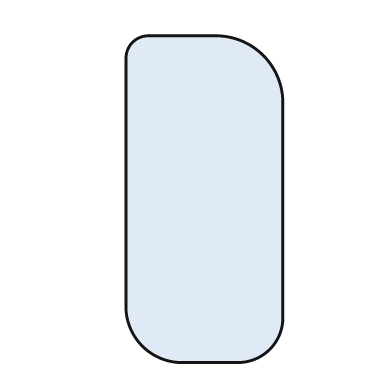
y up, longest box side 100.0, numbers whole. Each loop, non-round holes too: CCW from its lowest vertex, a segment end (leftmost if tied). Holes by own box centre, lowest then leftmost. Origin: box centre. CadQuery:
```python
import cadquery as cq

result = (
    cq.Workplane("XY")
    .moveTo(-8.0, -50.0)
    .lineTo(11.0, -50.0)
    .threePointArc((20.0, -46.0), (24.0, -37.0))
    .lineTo(24.0, 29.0)
    .threePointArc((18.0, 44.0), (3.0, 50.0))
    .lineTo(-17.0, 50.0)
    .threePointArc((-22.0, 48.0), (-24.0, 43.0))
    .lineTo(-24.0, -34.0)
    .threePointArc((-19.0, -45.0), (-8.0, -50.0))
    .close()
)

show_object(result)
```